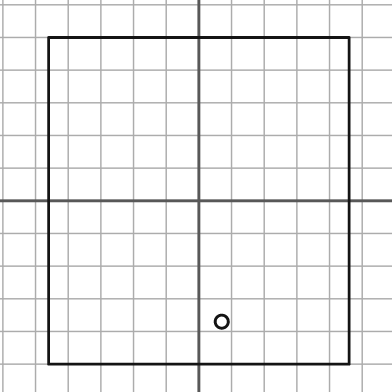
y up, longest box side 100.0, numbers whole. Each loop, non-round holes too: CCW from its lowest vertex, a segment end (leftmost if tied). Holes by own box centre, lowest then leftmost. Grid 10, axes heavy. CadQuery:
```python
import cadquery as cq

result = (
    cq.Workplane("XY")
    .moveTo(-46.0, -50.0)
    .lineTo(46.0, -50.0)
    .lineTo(46.0, 50.0)
    .lineTo(-46.0, 50.0)
    .close()
    .moveTo(7.0, -37.0)
    .circle(2.0)
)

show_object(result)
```